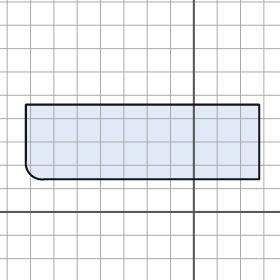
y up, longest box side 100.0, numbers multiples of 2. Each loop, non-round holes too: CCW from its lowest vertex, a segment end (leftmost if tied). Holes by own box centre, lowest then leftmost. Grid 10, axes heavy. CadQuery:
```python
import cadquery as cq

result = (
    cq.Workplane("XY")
    .moveTo(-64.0, 14.0)
    .lineTo(28.0, 14.0)
    .lineTo(28.0, 46.0)
    .lineTo(-72.0, 46.0)
    .lineTo(-72.0, 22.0)
    .threePointArc((-70.0, 16.0), (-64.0, 14.0))
    .close()
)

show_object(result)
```